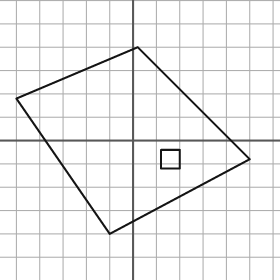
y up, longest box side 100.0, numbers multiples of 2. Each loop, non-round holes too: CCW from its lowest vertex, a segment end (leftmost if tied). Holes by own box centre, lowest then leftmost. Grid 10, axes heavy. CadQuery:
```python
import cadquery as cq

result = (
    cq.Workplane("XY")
    .moveTo(-10.0, -40.0)
    .lineTo(50.0, -8.0)
    .lineTo(2.0, 40.0)
    .lineTo(-50.0, 18.0)
    .close()
    .moveTo(12.0, -12.0)
    .lineTo(20.0, -12.0)
    .lineTo(20.0, -4.0)
    .lineTo(12.0, -4.0)
    .close()
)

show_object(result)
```